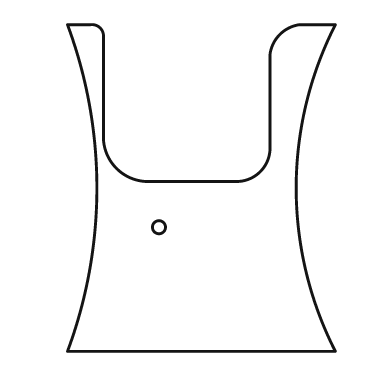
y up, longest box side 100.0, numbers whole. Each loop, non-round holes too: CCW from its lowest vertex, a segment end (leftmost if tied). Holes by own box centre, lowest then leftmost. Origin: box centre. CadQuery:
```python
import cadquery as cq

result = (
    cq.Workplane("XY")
    .moveTo(-41.0, -50.0)
    .lineTo(41.0, -50.0)
    .threePointArc((29.0, 0.0), (41.0, 50.0))
    .lineTo(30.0, 50.0)
    .threePointArc((24.0, 47.0), (21.0, 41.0))
    .lineTo(21.0, 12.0)
    .threePointArc((18.0, 5.0), (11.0, 2.0))
    .lineTo(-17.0, 2.0)
    .threePointArc((-26.0, 6.0), (-30.0, 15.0))
    .lineTo(-30.0, 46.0)
    .threePointArc((-31.0, 49.0), (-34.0, 50.0))
    .lineTo(-41.0, 50.0)
    .threePointArc((-32.0, 0.0), (-41.0, -50.0))
    .close()
    .moveTo(-13.0, -12.0)
    .circle(2.0)
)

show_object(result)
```